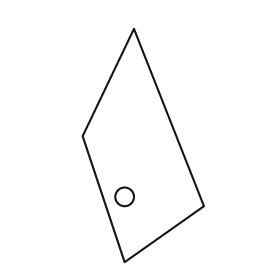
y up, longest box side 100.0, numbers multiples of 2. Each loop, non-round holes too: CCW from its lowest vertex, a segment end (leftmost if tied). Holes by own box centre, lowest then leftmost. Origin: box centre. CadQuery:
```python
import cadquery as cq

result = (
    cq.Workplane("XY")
    .moveTo(-8.0, -50.0)
    .lineTo(26.0, -26.0)
    .lineTo(-4.0, 50.0)
    .lineTo(-26.0, 4.0)
    .close()
    .moveTo(-8.0, -22.0)
    .circle(4.0)
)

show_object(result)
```